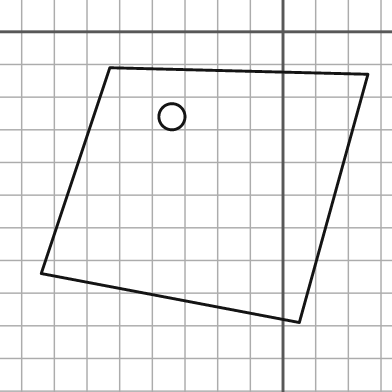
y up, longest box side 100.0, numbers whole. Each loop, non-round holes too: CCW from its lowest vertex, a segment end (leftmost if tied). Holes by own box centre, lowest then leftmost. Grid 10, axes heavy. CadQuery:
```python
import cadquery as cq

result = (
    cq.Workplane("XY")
    .moveTo(5.0, -89.0)
    .lineTo(26.0, -13.0)
    .lineTo(-53.0, -11.0)
    .lineTo(-74.0, -74.0)
    .close()
    .moveTo(-34.0, -26.0)
    .circle(4.0)
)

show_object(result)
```